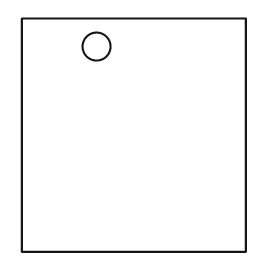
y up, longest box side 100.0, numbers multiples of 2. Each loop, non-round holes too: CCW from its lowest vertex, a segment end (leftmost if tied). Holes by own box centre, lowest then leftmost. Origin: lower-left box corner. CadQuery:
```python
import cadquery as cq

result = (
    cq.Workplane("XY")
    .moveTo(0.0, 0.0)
    .lineTo(96.0, 0.0)
    .lineTo(96.0, 100.0)
    .lineTo(0.0, 100.0)
    .close()
    .moveTo(32.0, 88.0)
    .circle(6.0)
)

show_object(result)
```